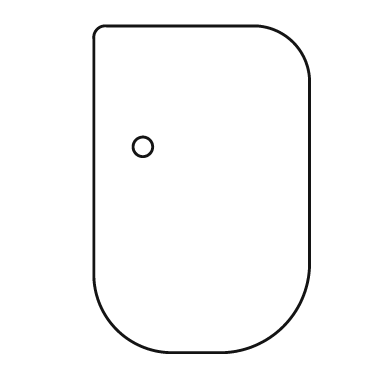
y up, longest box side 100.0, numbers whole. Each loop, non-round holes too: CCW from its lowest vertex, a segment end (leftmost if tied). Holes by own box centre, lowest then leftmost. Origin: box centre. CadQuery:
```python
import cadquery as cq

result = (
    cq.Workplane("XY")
    .moveTo(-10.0, -50.0)
    .lineTo(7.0, -50.0)
    .threePointArc((25.0, -42.0), (33.0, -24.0))
    .lineTo(33.0, 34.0)
    .threePointArc((28.0, 45.0), (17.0, 50.0))
    .lineTo(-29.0, 50.0)
    .threePointArc((-32.0, 49.0), (-33.0, 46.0))
    .lineTo(-33.0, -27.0)
    .threePointArc((-26.0, -43.0), (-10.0, -50.0))
    .close()
    .moveTo(-18.0, 13.0)
    .circle(3.0)
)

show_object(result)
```